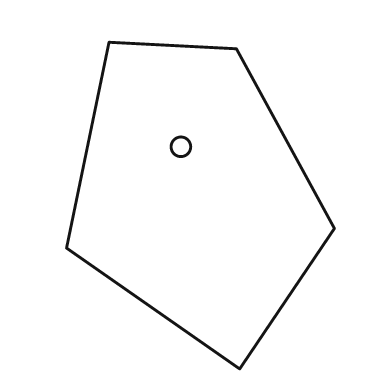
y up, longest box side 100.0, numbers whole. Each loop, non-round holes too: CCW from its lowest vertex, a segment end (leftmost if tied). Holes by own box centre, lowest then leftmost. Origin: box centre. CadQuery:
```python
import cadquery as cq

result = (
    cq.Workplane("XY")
    .moveTo(12.0, -50.0)
    .lineTo(41.0, -7.0)
    .lineTo(11.0, 48.0)
    .lineTo(-28.0, 50.0)
    .lineTo(-41.0, -13.0)
    .close()
    .moveTo(-6.0, 18.0)
    .circle(3.0)
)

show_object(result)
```